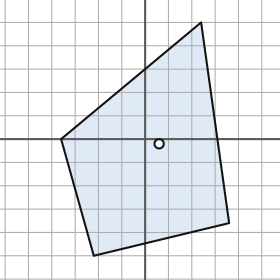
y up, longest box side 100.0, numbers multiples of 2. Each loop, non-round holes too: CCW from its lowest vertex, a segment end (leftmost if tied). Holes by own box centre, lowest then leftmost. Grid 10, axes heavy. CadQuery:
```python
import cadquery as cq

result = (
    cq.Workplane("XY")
    .moveTo(-22.0, -50.0)
    .lineTo(36.0, -36.0)
    .lineTo(24.0, 50.0)
    .lineTo(-36.0, 0.0)
    .close()
    .moveTo(6.0, -2.0)
    .circle(2.0)
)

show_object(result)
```